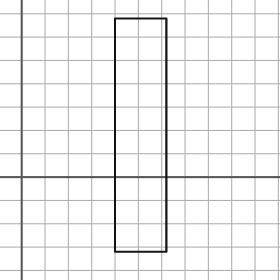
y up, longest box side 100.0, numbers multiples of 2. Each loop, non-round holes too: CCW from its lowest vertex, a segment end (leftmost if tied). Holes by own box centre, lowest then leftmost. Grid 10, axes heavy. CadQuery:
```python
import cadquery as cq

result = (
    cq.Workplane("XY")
    .moveTo(40.0, -32.0)
    .lineTo(62.0, -32.0)
    .lineTo(62.0, 68.0)
    .lineTo(40.0, 68.0)
    .close()
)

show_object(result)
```